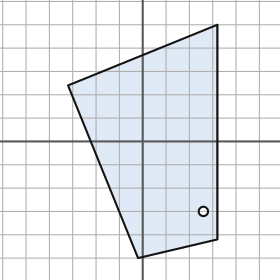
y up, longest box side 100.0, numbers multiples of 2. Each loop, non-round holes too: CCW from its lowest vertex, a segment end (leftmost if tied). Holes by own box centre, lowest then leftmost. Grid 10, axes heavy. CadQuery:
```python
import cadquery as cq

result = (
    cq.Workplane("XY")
    .moveTo(-2.0, -50.0)
    .lineTo(32.0, -42.0)
    .lineTo(32.0, 50.0)
    .lineTo(-32.0, 24.0)
    .close()
    .moveTo(26.0, -30.0)
    .circle(2.0)
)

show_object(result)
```